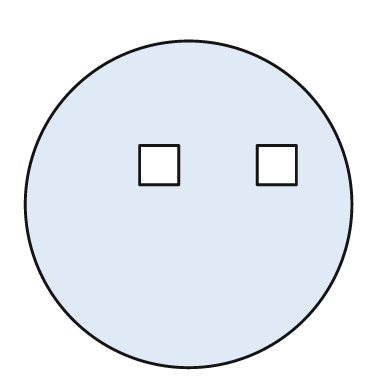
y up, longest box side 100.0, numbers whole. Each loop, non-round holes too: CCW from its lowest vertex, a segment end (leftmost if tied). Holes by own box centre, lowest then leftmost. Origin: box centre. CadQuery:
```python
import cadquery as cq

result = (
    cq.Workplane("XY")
    .moveTo(0.0, 0.0)
    .circle(50.0)
    .moveTo(-15.0, 6.0)
    .lineTo(-3.0, 6.0)
    .lineTo(-3.0, 18.0)
    .lineTo(-15.0, 18.0)
    .close()
    .moveTo(21.0, 6.0)
    .lineTo(33.0, 6.0)
    .lineTo(33.0, 18.0)
    .lineTo(21.0, 18.0)
    .close()
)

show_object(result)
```